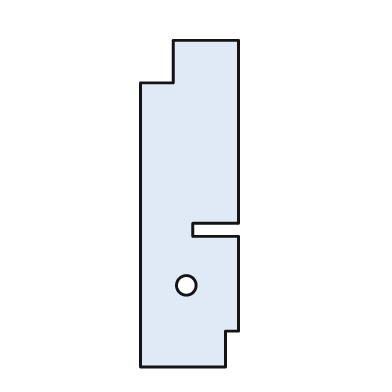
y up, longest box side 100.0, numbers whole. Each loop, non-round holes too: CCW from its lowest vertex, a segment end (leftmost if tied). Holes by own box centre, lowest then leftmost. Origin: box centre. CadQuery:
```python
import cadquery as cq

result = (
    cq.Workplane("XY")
    .moveTo(-15.0, -50.0)
    .lineTo(11.0, -50.0)
    .lineTo(11.0, -39.0)
    .lineTo(15.0, -39.0)
    .lineTo(15.0, -10.0)
    .lineTo(1.0, -10.0)
    .lineTo(1.0, -6.0)
    .lineTo(15.0, -6.0)
    .lineTo(15.0, 50.0)
    .lineTo(-5.0, 50.0)
    .lineTo(-5.0, 37.0)
    .lineTo(-15.0, 37.0)
    .close()
    .moveTo(-1.0, -25.0)
    .circle(3.0)
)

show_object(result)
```